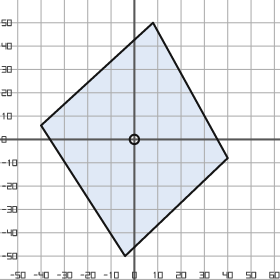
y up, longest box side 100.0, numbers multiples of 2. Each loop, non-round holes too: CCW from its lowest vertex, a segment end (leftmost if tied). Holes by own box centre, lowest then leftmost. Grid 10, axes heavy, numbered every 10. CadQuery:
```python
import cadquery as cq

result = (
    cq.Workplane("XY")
    .moveTo(-4.0, -50.0)
    .lineTo(40.0, -8.0)
    .lineTo(8.0, 50.0)
    .lineTo(-40.0, 6.0)
    .close()
    .moveTo(0.0, 0.0)
    .circle(2.0)
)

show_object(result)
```